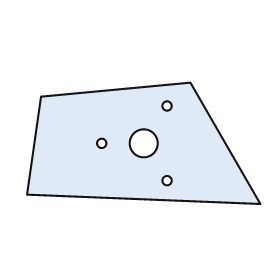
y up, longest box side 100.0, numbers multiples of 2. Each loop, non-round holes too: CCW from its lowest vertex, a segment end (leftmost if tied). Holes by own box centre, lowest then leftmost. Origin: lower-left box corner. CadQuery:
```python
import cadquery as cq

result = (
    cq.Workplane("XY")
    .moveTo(100.0, 0.0)
    .lineTo(70.0, 52.0)
    .lineTo(6.0, 46.0)
    .lineTo(0.0, 4.0)
    .close()
    .moveTo(60.0, 10.0)
    .circle(2.0)
    .moveTo(32.0, 26.0)
    .circle(2.0)
    .moveTo(50.0, 26.0)
    .circle(6.0)
    .moveTo(60.0, 42.0)
    .circle(2.0)
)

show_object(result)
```